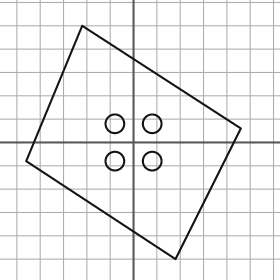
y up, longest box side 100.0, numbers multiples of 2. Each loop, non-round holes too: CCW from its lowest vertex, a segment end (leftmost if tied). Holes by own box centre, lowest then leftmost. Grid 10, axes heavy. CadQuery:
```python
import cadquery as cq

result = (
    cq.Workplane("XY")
    .moveTo(18.0, -50.0)
    .lineTo(46.0, 6.0)
    .lineTo(-22.0, 50.0)
    .lineTo(-46.0, -8.0)
    .close()
    .moveTo(-8.0, -8.0)
    .circle(4.0)
    .moveTo(8.0, -8.0)
    .circle(4.0)
    .moveTo(-8.0, 8.0)
    .circle(4.0)
    .moveTo(8.0, 8.0)
    .circle(4.0)
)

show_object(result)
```